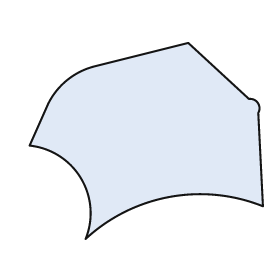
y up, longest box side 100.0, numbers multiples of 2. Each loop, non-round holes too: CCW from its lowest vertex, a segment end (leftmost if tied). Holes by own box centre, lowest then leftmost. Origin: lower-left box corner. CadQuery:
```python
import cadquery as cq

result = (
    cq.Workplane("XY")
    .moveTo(24.0, 0.0)
    .threePointArc((60.0, 18.0), (100.0, 14.0))
    .lineTo(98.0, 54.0)
    .threePointArc((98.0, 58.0), (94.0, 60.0))
    .lineTo(68.0, 84.0)
    .lineTo(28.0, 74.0)
    .threePointArc((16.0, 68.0), (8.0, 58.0))
    .lineTo(0.0, 40.0)
    .threePointArc((22.0, 26.0), (24.0, 0.0))
    .close()
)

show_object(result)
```